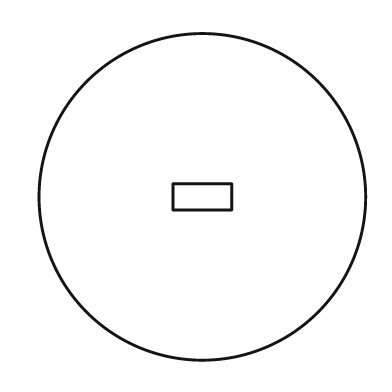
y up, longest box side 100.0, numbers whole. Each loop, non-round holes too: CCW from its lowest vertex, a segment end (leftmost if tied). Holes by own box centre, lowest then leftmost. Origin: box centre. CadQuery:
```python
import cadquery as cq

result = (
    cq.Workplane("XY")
    .moveTo(0.0, 0.0)
    .circle(50.0)
    .moveTo(-9.0, -4.0)
    .lineTo(9.0, -4.0)
    .lineTo(9.0, 4.0)
    .lineTo(-9.0, 4.0)
    .close()
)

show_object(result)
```